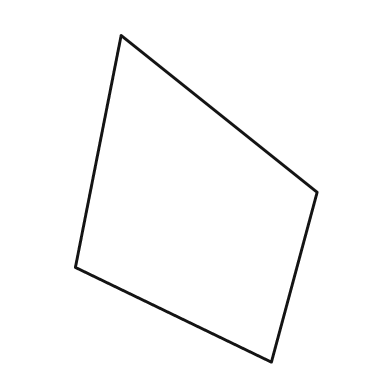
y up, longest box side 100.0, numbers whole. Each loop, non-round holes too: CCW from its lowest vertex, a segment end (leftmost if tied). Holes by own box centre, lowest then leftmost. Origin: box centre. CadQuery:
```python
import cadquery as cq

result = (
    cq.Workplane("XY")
    .moveTo(23.0, -50.0)
    .lineTo(37.0, 2.0)
    .lineTo(-23.0, 50.0)
    .lineTo(-37.0, -21.0)
    .close()
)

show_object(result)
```